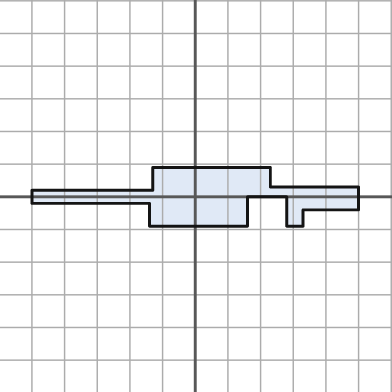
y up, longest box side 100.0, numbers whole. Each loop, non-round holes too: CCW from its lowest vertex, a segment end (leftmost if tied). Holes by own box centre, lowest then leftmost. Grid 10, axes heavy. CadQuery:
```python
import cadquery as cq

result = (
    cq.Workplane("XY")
    .moveTo(-14.0, -9.0)
    .lineTo(16.0, -9.0)
    .lineTo(16.0, 0.0)
    .lineTo(28.0, 0.0)
    .lineTo(28.0, -9.0)
    .lineTo(33.0, -9.0)
    .lineTo(33.0, -4.0)
    .lineTo(50.0, -4.0)
    .lineTo(50.0, 3.0)
    .lineTo(23.0, 3.0)
    .lineTo(23.0, 9.0)
    .lineTo(-13.0, 9.0)
    .lineTo(-13.0, 2.0)
    .lineTo(-50.0, 2.0)
    .lineTo(-50.0, -2.0)
    .lineTo(-14.0, -2.0)
    .close()
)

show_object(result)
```